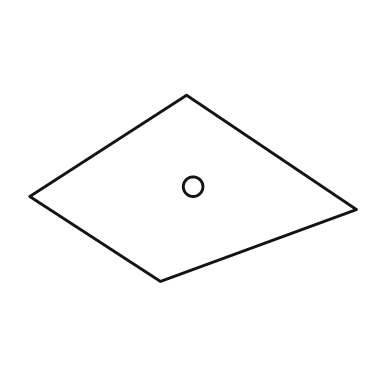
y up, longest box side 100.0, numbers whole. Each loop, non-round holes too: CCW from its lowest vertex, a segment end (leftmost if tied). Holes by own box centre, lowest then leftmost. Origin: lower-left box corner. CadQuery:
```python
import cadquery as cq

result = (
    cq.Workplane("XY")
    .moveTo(40.0, 0.0)
    .lineTo(100.0, 22.0)
    .lineTo(48.0, 57.0)
    .lineTo(0.0, 26.0)
    .close()
    .moveTo(50.0, 29.0)
    .circle(3.0)
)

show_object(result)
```